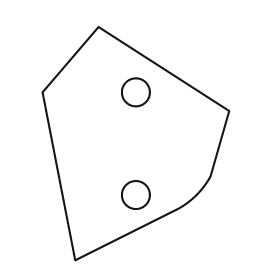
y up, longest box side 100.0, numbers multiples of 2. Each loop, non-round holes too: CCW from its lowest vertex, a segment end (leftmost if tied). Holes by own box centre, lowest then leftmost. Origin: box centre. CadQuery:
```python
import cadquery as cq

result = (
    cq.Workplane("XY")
    .moveTo(-26.0, -50.0)
    .lineTo(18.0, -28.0)
    .threePointArc((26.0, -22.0), (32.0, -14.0))
    .lineTo(40.0, 14.0)
    .lineTo(-16.0, 50.0)
    .lineTo(-40.0, 22.0)
    .close()
    .moveTo(0.0, -22.0)
    .circle(6.0)
    .moveTo(0.0, 22.0)
    .circle(6.0)
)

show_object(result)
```